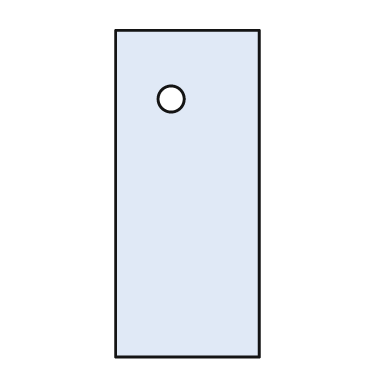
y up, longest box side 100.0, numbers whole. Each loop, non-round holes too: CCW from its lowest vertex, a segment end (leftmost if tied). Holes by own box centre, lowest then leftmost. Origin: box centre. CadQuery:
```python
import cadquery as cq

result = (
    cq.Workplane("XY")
    .moveTo(-22.0, -50.0)
    .lineTo(22.0, -50.0)
    .lineTo(22.0, 50.0)
    .lineTo(-22.0, 50.0)
    .close()
    .moveTo(-5.0, 29.0)
    .circle(4.0)
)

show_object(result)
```